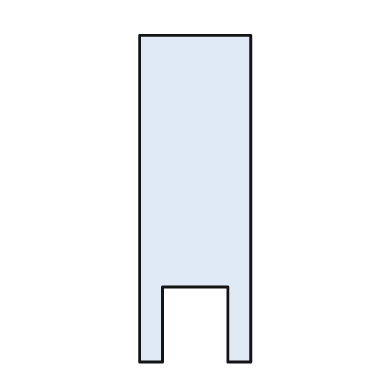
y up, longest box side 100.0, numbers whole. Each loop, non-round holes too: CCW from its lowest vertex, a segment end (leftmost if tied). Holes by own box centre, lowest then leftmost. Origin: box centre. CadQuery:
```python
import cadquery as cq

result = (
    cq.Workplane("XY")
    .moveTo(-17.0, -50.0)
    .lineTo(-10.0, -50.0)
    .lineTo(-10.0, -27.0)
    .lineTo(10.0, -27.0)
    .lineTo(10.0, -50.0)
    .lineTo(17.0, -50.0)
    .lineTo(17.0, 50.0)
    .lineTo(-17.0, 50.0)
    .close()
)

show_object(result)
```